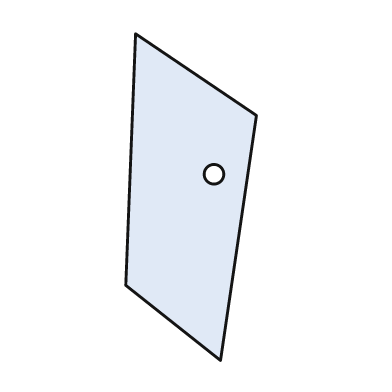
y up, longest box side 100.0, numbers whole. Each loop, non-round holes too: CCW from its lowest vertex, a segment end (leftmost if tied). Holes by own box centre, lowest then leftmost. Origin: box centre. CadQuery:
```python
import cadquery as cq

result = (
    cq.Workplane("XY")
    .moveTo(9.0, -50.0)
    .lineTo(20.0, 25.0)
    .lineTo(-17.0, 50.0)
    .lineTo(-20.0, -27.0)
    .close()
    .moveTo(7.0, 7.0)
    .circle(3.0)
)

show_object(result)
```